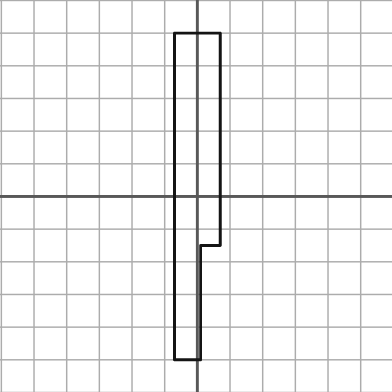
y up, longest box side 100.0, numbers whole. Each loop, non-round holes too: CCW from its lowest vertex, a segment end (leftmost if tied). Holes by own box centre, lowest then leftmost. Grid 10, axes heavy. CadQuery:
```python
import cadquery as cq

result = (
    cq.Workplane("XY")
    .moveTo(-7.0, -50.0)
    .lineTo(1.0, -50.0)
    .lineTo(1.0, -15.0)
    .lineTo(7.0, -15.0)
    .lineTo(7.0, 50.0)
    .lineTo(-7.0, 50.0)
    .close()
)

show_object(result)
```